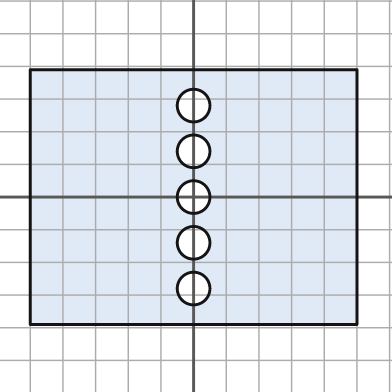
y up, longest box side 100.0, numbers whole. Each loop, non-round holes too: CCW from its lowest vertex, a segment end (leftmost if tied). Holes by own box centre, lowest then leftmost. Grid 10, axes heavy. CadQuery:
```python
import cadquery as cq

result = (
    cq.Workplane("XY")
    .moveTo(-50.0, -39.0)
    .lineTo(50.0, -39.0)
    .lineTo(50.0, 39.0)
    .lineTo(-50.0, 39.0)
    .close()
    .moveTo(0.0, -28.0)
    .circle(5.0)
    .moveTo(0.0, -14.0)
    .circle(5.0)
    .moveTo(0.0, 0.0)
    .circle(5.0)
    .moveTo(0.0, 14.0)
    .circle(5.0)
    .moveTo(0.0, 28.0)
    .circle(5.0)
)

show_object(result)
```